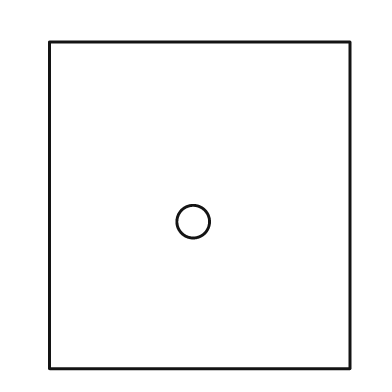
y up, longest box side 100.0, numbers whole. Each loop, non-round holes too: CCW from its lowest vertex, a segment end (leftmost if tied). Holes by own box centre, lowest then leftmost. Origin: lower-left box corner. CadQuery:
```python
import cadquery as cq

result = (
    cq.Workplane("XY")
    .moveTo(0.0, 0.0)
    .lineTo(92.0, 0.0)
    .lineTo(92.0, 100.0)
    .lineTo(0.0, 100.0)
    .close()
    .moveTo(44.0, 45.0)
    .circle(5.0)
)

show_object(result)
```